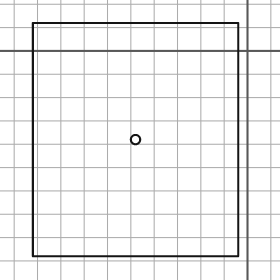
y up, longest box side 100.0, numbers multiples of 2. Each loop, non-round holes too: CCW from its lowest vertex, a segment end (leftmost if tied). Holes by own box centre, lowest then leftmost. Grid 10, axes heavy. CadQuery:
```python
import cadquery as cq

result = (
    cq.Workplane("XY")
    .moveTo(-92.0, -88.0)
    .lineTo(-4.0, -88.0)
    .lineTo(-4.0, 12.0)
    .lineTo(-92.0, 12.0)
    .close()
    .moveTo(-48.0, -38.0)
    .circle(2.0)
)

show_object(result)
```